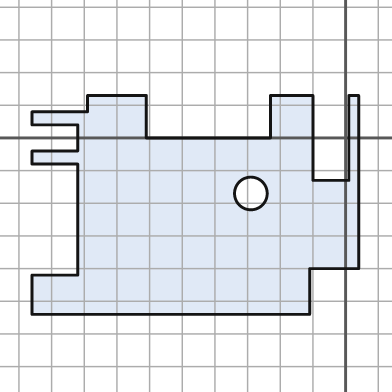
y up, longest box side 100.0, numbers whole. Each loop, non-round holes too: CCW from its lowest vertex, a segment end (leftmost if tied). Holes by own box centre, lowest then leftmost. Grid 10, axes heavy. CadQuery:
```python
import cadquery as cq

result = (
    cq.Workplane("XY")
    .moveTo(-96.0, -54.0)
    .lineTo(-11.0, -54.0)
    .lineTo(-11.0, -40.0)
    .lineTo(4.0, -40.0)
    .lineTo(4.0, 13.0)
    .lineTo(1.0, 13.0)
    .lineTo(1.0, -13.0)
    .lineTo(-10.0, -13.0)
    .lineTo(-10.0, 13.0)
    .lineTo(-23.0, 13.0)
    .lineTo(-23.0, 0.0)
    .lineTo(-61.0, 0.0)
    .lineTo(-61.0, 13.0)
    .lineTo(-79.0, 13.0)
    .lineTo(-79.0, 8.0)
    .lineTo(-96.0, 8.0)
    .lineTo(-96.0, 4.0)
    .lineTo(-82.0, 4.0)
    .lineTo(-82.0, -4.0)
    .lineTo(-96.0, -4.0)
    .lineTo(-96.0, -8.0)
    .lineTo(-82.0, -8.0)
    .lineTo(-82.0, -42.0)
    .lineTo(-96.0, -42.0)
    .close()
    .moveTo(-29.0, -17.0)
    .circle(5.0)
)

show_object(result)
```